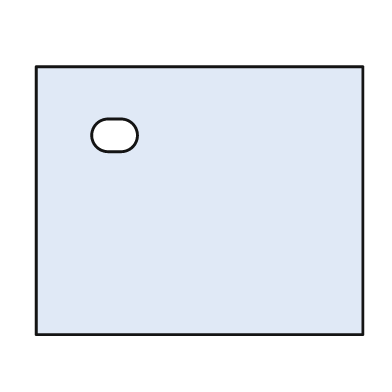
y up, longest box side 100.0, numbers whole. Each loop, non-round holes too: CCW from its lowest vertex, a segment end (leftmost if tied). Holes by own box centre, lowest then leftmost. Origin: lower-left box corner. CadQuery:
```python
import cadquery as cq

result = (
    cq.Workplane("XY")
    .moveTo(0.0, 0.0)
    .lineTo(100.0, 0.0)
    .lineTo(100.0, 82.0)
    .lineTo(0.0, 82.0)
    .close()
    .moveTo(22.0, 56.0)
    .lineTo(26.0, 56.0)
    .threePointArc((31.0, 61.0), (26.0, 66.0))
    .lineTo(22.0, 66.0)
    .threePointArc((17.0, 61.0), (22.0, 56.0))
    .close()
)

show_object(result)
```